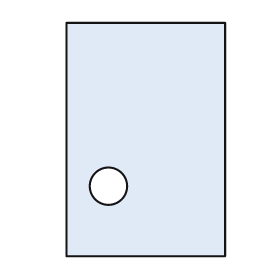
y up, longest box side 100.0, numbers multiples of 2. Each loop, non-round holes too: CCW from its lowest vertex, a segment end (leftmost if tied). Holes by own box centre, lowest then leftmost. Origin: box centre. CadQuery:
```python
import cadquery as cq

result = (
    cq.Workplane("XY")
    .moveTo(-34.0, -50.0)
    .lineTo(34.0, -50.0)
    .lineTo(34.0, 50.0)
    .lineTo(-34.0, 50.0)
    .close()
    .moveTo(-16.0, -20.0)
    .circle(8.0)
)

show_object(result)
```